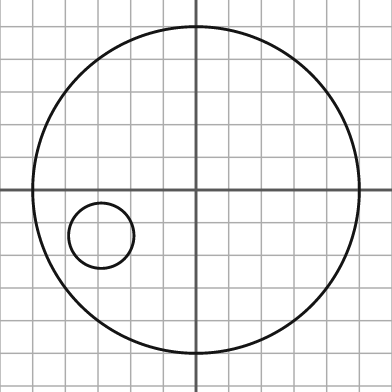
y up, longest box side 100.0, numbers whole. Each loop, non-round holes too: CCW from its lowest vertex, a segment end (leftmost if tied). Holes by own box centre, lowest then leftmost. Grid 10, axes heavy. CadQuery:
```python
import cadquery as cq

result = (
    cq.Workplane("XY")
    .moveTo(0.0, 0.0)
    .circle(50.0)
    .moveTo(-29.0, -14.0)
    .circle(10.0)
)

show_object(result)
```